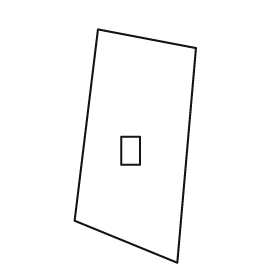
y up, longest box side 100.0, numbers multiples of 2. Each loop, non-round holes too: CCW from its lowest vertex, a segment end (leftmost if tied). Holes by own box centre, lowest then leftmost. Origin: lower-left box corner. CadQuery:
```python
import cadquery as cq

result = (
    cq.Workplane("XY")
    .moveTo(44.0, 0.0)
    .lineTo(52.0, 92.0)
    .lineTo(10.0, 100.0)
    .lineTo(0.0, 18.0)
    .close()
    .moveTo(20.0, 42.0)
    .lineTo(28.0, 42.0)
    .lineTo(28.0, 54.0)
    .lineTo(20.0, 54.0)
    .close()
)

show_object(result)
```